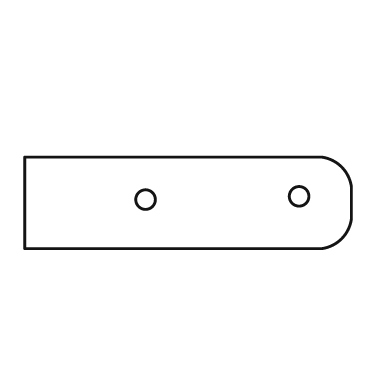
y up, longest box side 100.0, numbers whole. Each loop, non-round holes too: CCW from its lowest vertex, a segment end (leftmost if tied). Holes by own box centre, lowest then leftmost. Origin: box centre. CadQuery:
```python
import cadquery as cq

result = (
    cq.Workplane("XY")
    .moveTo(-50.0, -14.0)
    .lineTo(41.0, -14.0)
    .threePointArc((47.0, -11.0), (50.0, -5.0))
    .lineTo(50.0, 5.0)
    .threePointArc((47.0, 11.0), (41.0, 14.0))
    .lineTo(-50.0, 14.0)
    .close()
    .moveTo(-13.0, 1.0)
    .circle(3.0)
    .moveTo(34.0, 2.0)
    .circle(3.0)
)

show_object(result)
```